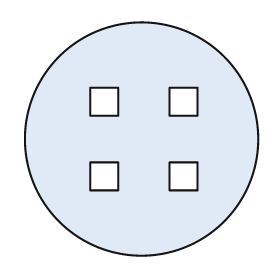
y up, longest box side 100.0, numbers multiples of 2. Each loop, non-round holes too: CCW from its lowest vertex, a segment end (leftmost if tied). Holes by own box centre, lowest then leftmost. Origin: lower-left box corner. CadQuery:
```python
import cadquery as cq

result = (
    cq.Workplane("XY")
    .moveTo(50.0, 50.0)
    .circle(50.0)
    .moveTo(28.0, 28.0)
    .lineTo(40.0, 28.0)
    .lineTo(40.0, 40.0)
    .lineTo(28.0, 40.0)
    .close()
    .moveTo(62.0, 28.0)
    .lineTo(74.0, 28.0)
    .lineTo(74.0, 40.0)
    .lineTo(62.0, 40.0)
    .close()
    .moveTo(28.0, 60.0)
    .lineTo(40.0, 60.0)
    .lineTo(40.0, 72.0)
    .lineTo(28.0, 72.0)
    .close()
    .moveTo(62.0, 60.0)
    .lineTo(74.0, 60.0)
    .lineTo(74.0, 72.0)
    .lineTo(62.0, 72.0)
    .close()
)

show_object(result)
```